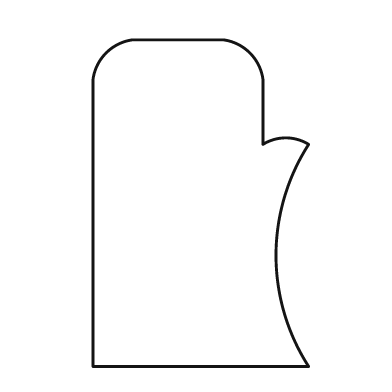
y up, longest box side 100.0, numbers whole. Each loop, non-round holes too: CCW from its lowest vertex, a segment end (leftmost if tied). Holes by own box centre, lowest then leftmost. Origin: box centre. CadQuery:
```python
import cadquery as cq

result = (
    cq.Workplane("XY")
    .moveTo(-33.0, -50.0)
    .lineTo(33.0, -50.0)
    .threePointArc((23.0, -16.0), (33.0, 18.0))
    .threePointArc((26.0, 20.0), (19.0, 18.0))
    .lineTo(19.0, 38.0)
    .threePointArc((15.0, 46.0), (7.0, 50.0))
    .lineTo(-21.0, 50.0)
    .threePointArc((-29.0, 46.0), (-33.0, 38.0))
    .close()
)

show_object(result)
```